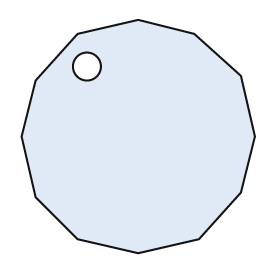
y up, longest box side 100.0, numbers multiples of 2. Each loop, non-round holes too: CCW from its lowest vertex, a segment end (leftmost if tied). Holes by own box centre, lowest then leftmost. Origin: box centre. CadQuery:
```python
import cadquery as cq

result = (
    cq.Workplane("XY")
    .moveTo(0.0, -50.0)
    .lineTo(26.0, -44.0)
    .lineTo(44.0, -24.0)
    .lineTo(50.0, 0.0)
    .lineTo(44.0, 26.0)
    .lineTo(24.0, 44.0)
    .lineTo(0.0, 50.0)
    .lineTo(-26.0, 44.0)
    .lineTo(-44.0, 24.0)
    .lineTo(-50.0, 0.0)
    .lineTo(-44.0, -26.0)
    .lineTo(-26.0, -44.0)
    .close()
    .moveTo(-22.0, 30.0)
    .circle(6.0)
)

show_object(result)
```